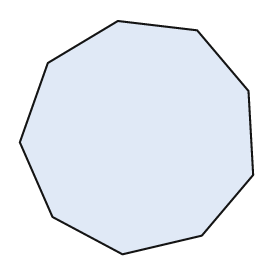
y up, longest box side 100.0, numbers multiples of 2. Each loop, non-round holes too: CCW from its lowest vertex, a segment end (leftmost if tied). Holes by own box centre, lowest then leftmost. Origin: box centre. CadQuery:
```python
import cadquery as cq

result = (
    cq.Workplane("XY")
    .moveTo(-6.0, -50.0)
    .lineTo(28.0, -42.0)
    .lineTo(50.0, -16.0)
    .lineTo(48.0, 20.0)
    .lineTo(26.0, 46.0)
    .lineTo(-8.0, 50.0)
    .lineTo(-38.0, 32.0)
    .lineTo(-50.0, -2.0)
    .lineTo(-36.0, -34.0)
    .close()
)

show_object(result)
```